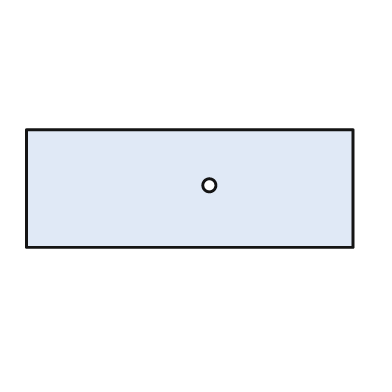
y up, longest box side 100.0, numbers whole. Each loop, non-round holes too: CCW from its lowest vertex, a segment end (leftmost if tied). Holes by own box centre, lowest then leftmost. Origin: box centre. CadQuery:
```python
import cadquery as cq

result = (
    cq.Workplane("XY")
    .moveTo(-50.0, -18.0)
    .lineTo(50.0, -18.0)
    .lineTo(50.0, 18.0)
    .lineTo(-50.0, 18.0)
    .close()
    .moveTo(6.0, 1.0)
    .circle(2.0)
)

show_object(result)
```